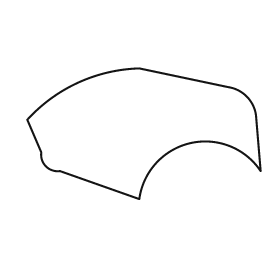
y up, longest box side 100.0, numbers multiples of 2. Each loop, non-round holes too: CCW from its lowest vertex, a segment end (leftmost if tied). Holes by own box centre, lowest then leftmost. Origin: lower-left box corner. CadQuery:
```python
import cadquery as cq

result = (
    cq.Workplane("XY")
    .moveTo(48.0, 0.0)
    .threePointArc((70.0, 24.0), (100.0, 12.0))
    .lineTo(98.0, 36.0)
    .threePointArc((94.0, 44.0), (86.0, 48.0))
    .lineTo(48.0, 56.0)
    .threePointArc((22.0, 50.0), (0.0, 34.0))
    .lineTo(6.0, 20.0)
    .threePointArc((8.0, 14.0), (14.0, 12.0))
    .close()
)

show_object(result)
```